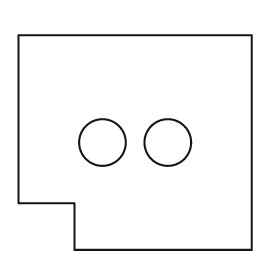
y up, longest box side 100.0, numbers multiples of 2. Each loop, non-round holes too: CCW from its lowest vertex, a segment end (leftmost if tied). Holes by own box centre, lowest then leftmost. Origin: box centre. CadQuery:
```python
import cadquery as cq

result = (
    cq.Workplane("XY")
    .moveTo(-26.0, -46.0)
    .lineTo(50.0, -46.0)
    .lineTo(50.0, 46.0)
    .lineTo(-50.0, 46.0)
    .lineTo(-50.0, -26.0)
    .lineTo(-26.0, -26.0)
    .close()
    .moveTo(-14.0, 0.0)
    .circle(10.0)
    .moveTo(14.0, 0.0)
    .circle(10.0)
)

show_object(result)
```